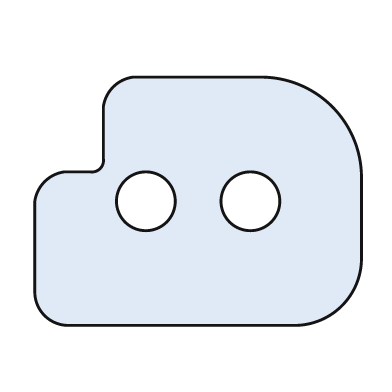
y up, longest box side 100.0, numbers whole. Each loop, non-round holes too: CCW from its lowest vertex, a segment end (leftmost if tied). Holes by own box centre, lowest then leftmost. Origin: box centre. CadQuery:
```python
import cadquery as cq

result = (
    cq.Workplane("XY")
    .moveTo(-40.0, -38.0)
    .lineTo(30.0, -38.0)
    .threePointArc((44.0, -32.0), (50.0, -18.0))
    .lineTo(50.0, 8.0)
    .threePointArc((41.0, 29.0), (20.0, 38.0))
    .lineTo(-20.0, 38.0)
    .threePointArc((-26.0, 35.0), (-29.0, 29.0))
    .lineTo(-29.0, 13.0)
    .threePointArc((-30.0, 10.0), (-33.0, 9.0))
    .lineTo(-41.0, 9.0)
    .threePointArc((-47.0, 6.0), (-50.0, 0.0))
    .lineTo(-50.0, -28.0)
    .threePointArc((-47.0, -35.0), (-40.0, -38.0))
    .close()
    .moveTo(-16.0, 0.0)
    .circle(9.0)
    .moveTo(16.0, 0.0)
    .circle(9.0)
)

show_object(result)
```